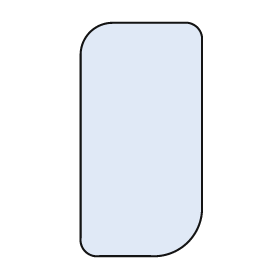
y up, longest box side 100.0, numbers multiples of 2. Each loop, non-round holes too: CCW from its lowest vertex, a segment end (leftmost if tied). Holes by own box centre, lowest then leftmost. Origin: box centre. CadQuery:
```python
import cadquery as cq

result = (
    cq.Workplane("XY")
    .moveTo(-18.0, -50.0)
    .lineTo(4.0, -50.0)
    .threePointArc((20.0, -44.0), (26.0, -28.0))
    .lineTo(26.0, 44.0)
    .threePointArc((24.0, 48.0), (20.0, 50.0))
    .lineTo(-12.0, 50.0)
    .threePointArc((-22.0, 46.0), (-26.0, 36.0))
    .lineTo(-26.0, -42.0)
    .threePointArc((-24.0, -48.0), (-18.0, -50.0))
    .close()
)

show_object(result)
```